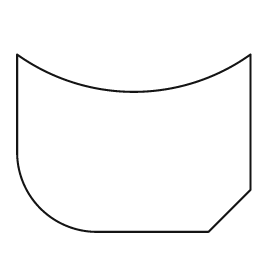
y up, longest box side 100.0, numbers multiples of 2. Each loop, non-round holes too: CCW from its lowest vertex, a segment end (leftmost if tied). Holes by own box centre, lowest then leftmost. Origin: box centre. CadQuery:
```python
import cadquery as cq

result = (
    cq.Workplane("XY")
    .moveTo(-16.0, -38.0)
    .lineTo(32.0, -38.0)
    .lineTo(50.0, -20.0)
    .lineTo(50.0, 38.0)
    .threePointArc((0.0, 22.0), (-50.0, 38.0))
    .lineTo(-50.0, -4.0)
    .threePointArc((-40.0, -28.0), (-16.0, -38.0))
    .close()
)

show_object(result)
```